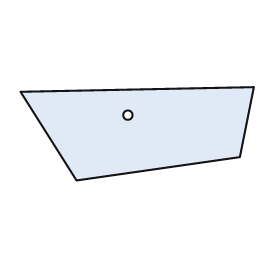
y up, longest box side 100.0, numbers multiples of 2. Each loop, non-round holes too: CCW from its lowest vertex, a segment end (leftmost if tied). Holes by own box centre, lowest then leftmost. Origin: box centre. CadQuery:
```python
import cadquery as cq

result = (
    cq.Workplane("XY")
    .moveTo(-26.0, -20.0)
    .lineTo(44.0, -10.0)
    .lineTo(50.0, 20.0)
    .lineTo(-50.0, 18.0)
    .close()
    .moveTo(-4.0, 8.0)
    .circle(2.0)
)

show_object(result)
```